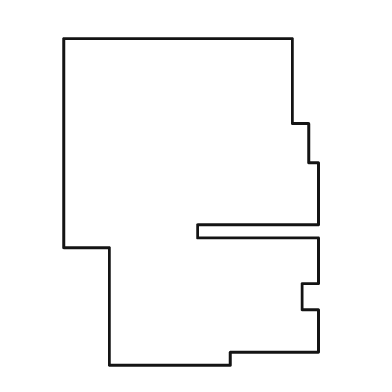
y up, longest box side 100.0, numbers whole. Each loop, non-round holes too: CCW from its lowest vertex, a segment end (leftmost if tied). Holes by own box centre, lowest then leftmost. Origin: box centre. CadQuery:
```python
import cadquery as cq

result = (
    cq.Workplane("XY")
    .moveTo(-25.0, -50.0)
    .lineTo(12.0, -50.0)
    .lineTo(12.0, -46.0)
    .lineTo(39.0, -46.0)
    .lineTo(39.0, -33.0)
    .lineTo(34.0, -33.0)
    .lineTo(34.0, -25.0)
    .lineTo(39.0, -25.0)
    .lineTo(39.0, -11.0)
    .lineTo(2.0, -11.0)
    .lineTo(2.0, -7.0)
    .lineTo(39.0, -7.0)
    .lineTo(39.0, 12.0)
    .lineTo(36.0, 12.0)
    .lineTo(36.0, 24.0)
    .lineTo(31.0, 24.0)
    .lineTo(31.0, 50.0)
    .lineTo(-39.0, 50.0)
    .lineTo(-39.0, -14.0)
    .lineTo(-25.0, -14.0)
    .close()
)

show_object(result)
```